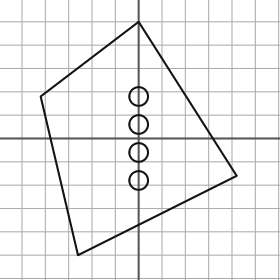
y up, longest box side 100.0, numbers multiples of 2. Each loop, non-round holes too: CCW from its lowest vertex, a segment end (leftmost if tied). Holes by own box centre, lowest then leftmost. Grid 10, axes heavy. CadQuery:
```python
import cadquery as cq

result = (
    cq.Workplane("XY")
    .moveTo(-26.0, -50.0)
    .lineTo(42.0, -16.0)
    .lineTo(0.0, 50.0)
    .lineTo(-42.0, 18.0)
    .close()
    .moveTo(0.0, -18.0)
    .circle(4.0)
    .moveTo(0.0, -6.0)
    .circle(4.0)
    .moveTo(0.0, 6.0)
    .circle(4.0)
    .moveTo(0.0, 18.0)
    .circle(4.0)
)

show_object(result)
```